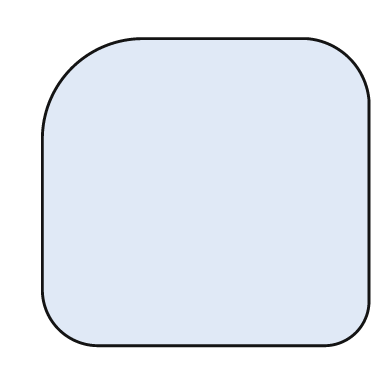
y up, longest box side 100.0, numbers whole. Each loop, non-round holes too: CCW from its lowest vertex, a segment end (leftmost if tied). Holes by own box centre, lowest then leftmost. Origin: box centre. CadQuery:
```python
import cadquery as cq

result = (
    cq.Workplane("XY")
    .moveTo(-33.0, -47.0)
    .lineTo(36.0, -47.0)
    .threePointArc((46.0, -43.0), (50.0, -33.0))
    .lineTo(50.0, 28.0)
    .threePointArc((44.0, 41.0), (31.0, 47.0))
    .lineTo(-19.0, 47.0)
    .threePointArc((-41.0, 38.0), (-50.0, 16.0))
    .lineTo(-50.0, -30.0)
    .threePointArc((-45.0, -42.0), (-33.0, -47.0))
    .close()
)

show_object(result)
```